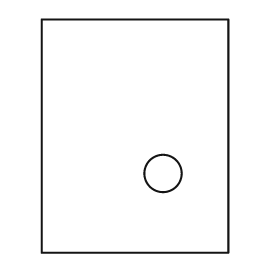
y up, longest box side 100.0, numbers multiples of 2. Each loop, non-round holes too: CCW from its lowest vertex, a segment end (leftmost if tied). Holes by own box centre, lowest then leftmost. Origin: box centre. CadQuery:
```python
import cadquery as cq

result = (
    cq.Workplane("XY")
    .moveTo(-40.0, -50.0)
    .lineTo(40.0, -50.0)
    .lineTo(40.0, 50.0)
    .lineTo(-40.0, 50.0)
    .close()
    .moveTo(12.0, -16.0)
    .circle(8.0)
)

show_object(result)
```